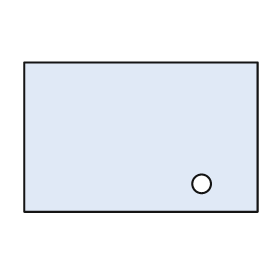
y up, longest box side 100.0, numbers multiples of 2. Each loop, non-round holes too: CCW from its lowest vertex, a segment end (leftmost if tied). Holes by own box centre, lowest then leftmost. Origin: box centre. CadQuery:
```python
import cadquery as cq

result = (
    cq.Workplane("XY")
    .moveTo(-50.0, -32.0)
    .lineTo(50.0, -32.0)
    .lineTo(50.0, 32.0)
    .lineTo(-50.0, 32.0)
    .close()
    .moveTo(26.0, -20.0)
    .circle(4.0)
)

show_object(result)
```